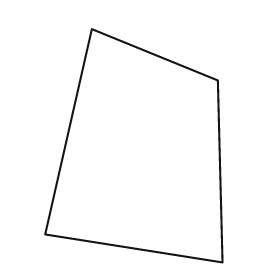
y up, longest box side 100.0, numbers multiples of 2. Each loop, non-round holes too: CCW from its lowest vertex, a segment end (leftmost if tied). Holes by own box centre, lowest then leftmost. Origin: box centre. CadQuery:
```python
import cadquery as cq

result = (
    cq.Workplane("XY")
    .moveTo(38.0, -50.0)
    .lineTo(36.0, 28.0)
    .lineTo(-18.0, 50.0)
    .lineTo(-38.0, -38.0)
    .close()
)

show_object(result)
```